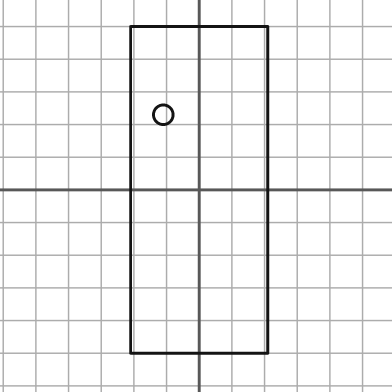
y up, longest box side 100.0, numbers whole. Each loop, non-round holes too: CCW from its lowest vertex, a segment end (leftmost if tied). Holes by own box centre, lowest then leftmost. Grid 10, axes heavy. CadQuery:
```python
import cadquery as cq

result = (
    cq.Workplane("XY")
    .moveTo(-21.0, -50.0)
    .lineTo(21.0, -50.0)
    .lineTo(21.0, 50.0)
    .lineTo(-21.0, 50.0)
    .close()
    .moveTo(-11.0, 23.0)
    .circle(3.0)
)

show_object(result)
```